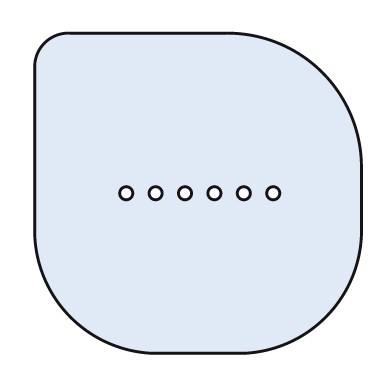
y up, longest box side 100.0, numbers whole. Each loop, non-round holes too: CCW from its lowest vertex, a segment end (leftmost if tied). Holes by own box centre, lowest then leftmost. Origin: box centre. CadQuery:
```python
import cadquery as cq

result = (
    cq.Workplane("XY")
    .moveTo(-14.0, -49.0)
    .lineTo(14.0, -49.0)
    .threePointArc((39.0, -38.0), (50.0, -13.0))
    .lineTo(50.0, 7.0)
    .threePointArc((38.0, 37.0), (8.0, 49.0))
    .lineTo(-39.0, 49.0)
    .threePointArc((-47.0, 46.0), (-50.0, 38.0))
    .lineTo(-50.0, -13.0)
    .threePointArc((-39.0, -38.0), (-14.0, -49.0))
    .close()
    .moveTo(-22.0, 0.0)
    .circle(2.0)
    .moveTo(-13.0, 0.0)
    .circle(2.0)
    .moveTo(-4.0, 0.0)
    .circle(2.0)
    .moveTo(5.0, 0.0)
    .circle(2.0)
    .moveTo(14.0, 0.0)
    .circle(2.0)
    .moveTo(23.0, 0.0)
    .circle(2.0)
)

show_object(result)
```